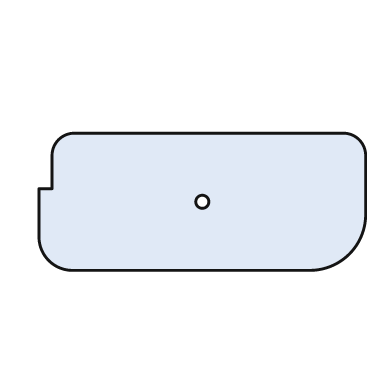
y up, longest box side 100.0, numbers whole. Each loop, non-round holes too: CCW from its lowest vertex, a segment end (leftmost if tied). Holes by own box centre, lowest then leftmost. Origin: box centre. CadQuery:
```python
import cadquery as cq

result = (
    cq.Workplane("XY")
    .moveTo(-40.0, -21.0)
    .lineTo(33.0, -21.0)
    .threePointArc((45.0, -16.0), (50.0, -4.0))
    .lineTo(50.0, 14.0)
    .threePointArc((48.0, 19.0), (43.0, 21.0))
    .lineTo(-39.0, 21.0)
    .threePointArc((-44.0, 19.0), (-46.0, 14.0))
    .lineTo(-46.0, 4.0)
    .lineTo(-50.0, 4.0)
    .lineTo(-50.0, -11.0)
    .threePointArc((-47.0, -18.0), (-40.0, -21.0))
    .close()
    .moveTo(0.0, 0.0)
    .circle(2.0)
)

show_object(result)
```